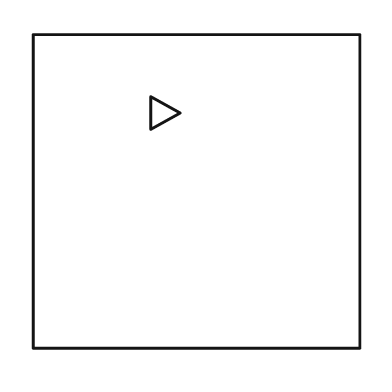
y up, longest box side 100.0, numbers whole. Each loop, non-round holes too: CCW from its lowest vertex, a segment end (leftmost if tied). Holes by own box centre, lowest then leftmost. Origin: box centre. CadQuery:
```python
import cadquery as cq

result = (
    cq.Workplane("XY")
    .moveTo(-50.0, -48.0)
    .lineTo(50.0, -48.0)
    .lineTo(50.0, 48.0)
    .lineTo(-50.0, 48.0)
    .close()
    .moveTo(-14.0, 19.0)
    .lineTo(-5.0, 24.0)
    .lineTo(-14.0, 29.0)
    .close()
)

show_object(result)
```